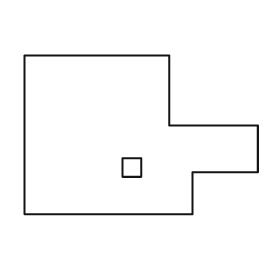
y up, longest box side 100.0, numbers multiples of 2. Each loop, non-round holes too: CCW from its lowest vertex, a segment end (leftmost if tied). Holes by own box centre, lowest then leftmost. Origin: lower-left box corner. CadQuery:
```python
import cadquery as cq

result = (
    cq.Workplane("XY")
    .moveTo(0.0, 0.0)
    .lineTo(72.0, 0.0)
    .lineTo(72.0, 18.0)
    .lineTo(100.0, 18.0)
    .lineTo(100.0, 38.0)
    .lineTo(62.0, 38.0)
    .lineTo(62.0, 68.0)
    .lineTo(0.0, 68.0)
    .close()
    .moveTo(42.0, 16.0)
    .lineTo(50.0, 16.0)
    .lineTo(50.0, 24.0)
    .lineTo(42.0, 24.0)
    .close()
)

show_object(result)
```